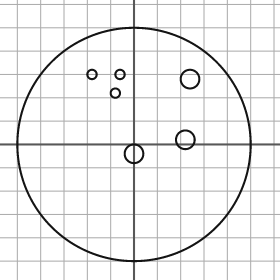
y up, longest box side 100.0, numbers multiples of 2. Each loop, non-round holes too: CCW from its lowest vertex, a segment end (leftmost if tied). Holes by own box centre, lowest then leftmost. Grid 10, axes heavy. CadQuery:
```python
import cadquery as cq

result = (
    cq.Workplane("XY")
    .moveTo(0.0, 0.0)
    .circle(50.0)
    .moveTo(0.0, -4.0)
    .circle(4.0)
    .moveTo(22.0, 2.0)
    .circle(4.0)
    .moveTo(-8.0, 22.0)
    .circle(2.0)
    .moveTo(24.0, 28.0)
    .circle(4.0)
    .moveTo(-18.0, 30.0)
    .circle(2.0)
    .moveTo(-6.0, 30.0)
    .circle(2.0)
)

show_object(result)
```